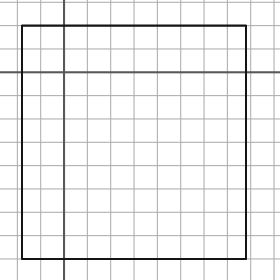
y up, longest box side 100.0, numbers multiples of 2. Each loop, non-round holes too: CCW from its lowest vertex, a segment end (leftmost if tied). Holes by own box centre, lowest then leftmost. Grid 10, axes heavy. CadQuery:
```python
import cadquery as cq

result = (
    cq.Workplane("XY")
    .moveTo(-18.0, -80.0)
    .lineTo(78.0, -80.0)
    .lineTo(78.0, 20.0)
    .lineTo(-18.0, 20.0)
    .close()
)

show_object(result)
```